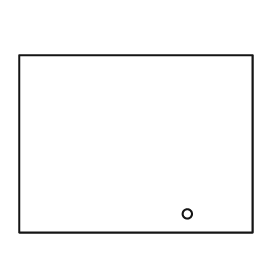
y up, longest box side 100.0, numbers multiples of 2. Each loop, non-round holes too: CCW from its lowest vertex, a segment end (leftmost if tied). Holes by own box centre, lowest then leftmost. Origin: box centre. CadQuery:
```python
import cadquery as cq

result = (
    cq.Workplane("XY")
    .moveTo(-50.0, -38.0)
    .lineTo(50.0, -38.0)
    .lineTo(50.0, 38.0)
    .lineTo(-50.0, 38.0)
    .close()
    .moveTo(22.0, -30.0)
    .circle(2.0)
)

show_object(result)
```